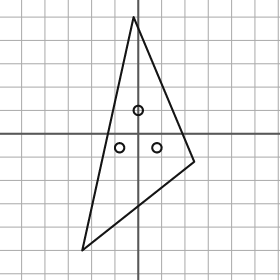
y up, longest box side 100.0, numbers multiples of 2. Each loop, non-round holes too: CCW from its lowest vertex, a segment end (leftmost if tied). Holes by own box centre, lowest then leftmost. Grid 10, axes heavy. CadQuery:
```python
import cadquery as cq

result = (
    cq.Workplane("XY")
    .moveTo(-24.0, -50.0)
    .lineTo(24.0, -12.0)
    .lineTo(-2.0, 50.0)
    .close()
    .moveTo(-8.0, -6.0)
    .circle(2.0)
    .moveTo(8.0, -6.0)
    .circle(2.0)
    .moveTo(0.0, 10.0)
    .circle(2.0)
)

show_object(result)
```